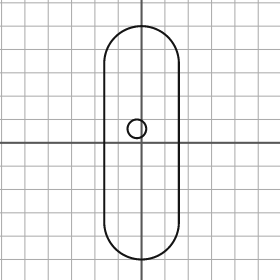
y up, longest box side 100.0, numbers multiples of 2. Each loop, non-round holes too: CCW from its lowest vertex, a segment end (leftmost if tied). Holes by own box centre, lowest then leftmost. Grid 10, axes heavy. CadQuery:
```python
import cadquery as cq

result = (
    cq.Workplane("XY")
    .moveTo(-16.0, -34.0)
    .threePointArc((0.0, -50.0), (16.0, -34.0))
    .lineTo(16.0, 34.0)
    .threePointArc((0.0, 50.0), (-16.0, 34.0))
    .close()
    .moveTo(-2.0, 6.0)
    .circle(4.0)
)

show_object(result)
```